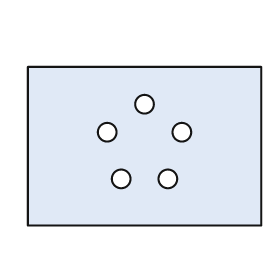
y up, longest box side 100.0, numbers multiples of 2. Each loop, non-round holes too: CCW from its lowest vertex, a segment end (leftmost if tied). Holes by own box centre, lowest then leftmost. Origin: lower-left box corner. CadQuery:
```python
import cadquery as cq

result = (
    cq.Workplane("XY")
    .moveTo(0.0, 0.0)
    .lineTo(100.0, 0.0)
    .lineTo(100.0, 68.0)
    .lineTo(0.0, 68.0)
    .close()
    .moveTo(40.0, 20.0)
    .circle(4.0)
    .moveTo(60.0, 20.0)
    .circle(4.0)
    .moveTo(34.0, 40.0)
    .circle(4.0)
    .moveTo(66.0, 40.0)
    .circle(4.0)
    .moveTo(50.0, 52.0)
    .circle(4.0)
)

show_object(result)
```